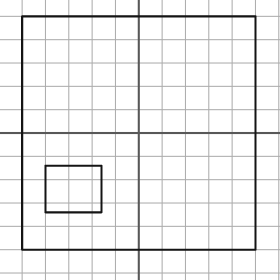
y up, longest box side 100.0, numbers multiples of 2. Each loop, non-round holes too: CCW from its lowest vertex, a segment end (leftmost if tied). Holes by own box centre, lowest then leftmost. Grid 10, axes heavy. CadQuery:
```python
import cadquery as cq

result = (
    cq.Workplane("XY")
    .moveTo(-50.0, -50.0)
    .lineTo(50.0, -50.0)
    .lineTo(50.0, 50.0)
    .lineTo(-50.0, 50.0)
    .close()
    .moveTo(-40.0, -34.0)
    .lineTo(-16.0, -34.0)
    .lineTo(-16.0, -14.0)
    .lineTo(-40.0, -14.0)
    .close()
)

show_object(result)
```